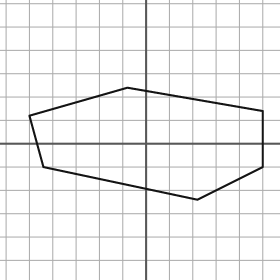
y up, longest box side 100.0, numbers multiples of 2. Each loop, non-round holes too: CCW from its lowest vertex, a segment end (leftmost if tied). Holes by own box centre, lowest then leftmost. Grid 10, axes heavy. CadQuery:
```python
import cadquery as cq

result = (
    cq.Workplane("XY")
    .moveTo(22.0, -24.0)
    .lineTo(50.0, -10.0)
    .lineTo(50.0, 14.0)
    .lineTo(-8.0, 24.0)
    .lineTo(-50.0, 12.0)
    .lineTo(-44.0, -10.0)
    .close()
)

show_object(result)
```